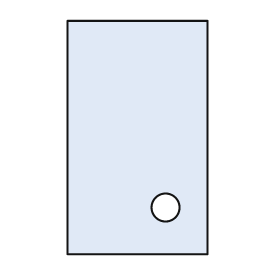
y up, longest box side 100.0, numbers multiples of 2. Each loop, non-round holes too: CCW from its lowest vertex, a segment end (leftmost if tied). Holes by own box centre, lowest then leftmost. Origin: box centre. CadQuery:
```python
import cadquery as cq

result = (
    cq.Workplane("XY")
    .moveTo(-30.0, -50.0)
    .lineTo(30.0, -50.0)
    .lineTo(30.0, 50.0)
    .lineTo(-30.0, 50.0)
    .close()
    .moveTo(12.0, -30.0)
    .circle(6.0)
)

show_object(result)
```